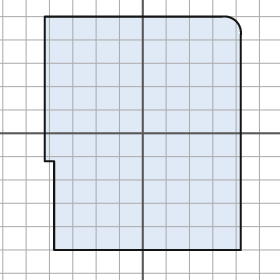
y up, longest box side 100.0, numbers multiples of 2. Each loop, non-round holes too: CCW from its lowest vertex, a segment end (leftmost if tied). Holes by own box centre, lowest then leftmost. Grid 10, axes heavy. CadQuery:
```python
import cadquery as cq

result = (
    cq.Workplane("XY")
    .moveTo(-38.0, -50.0)
    .lineTo(42.0, -50.0)
    .lineTo(42.0, 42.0)
    .threePointArc((40.0, 48.0), (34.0, 50.0))
    .lineTo(-42.0, 50.0)
    .lineTo(-42.0, -12.0)
    .lineTo(-38.0, -12.0)
    .close()
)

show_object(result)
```